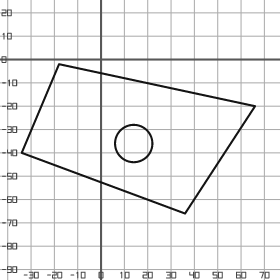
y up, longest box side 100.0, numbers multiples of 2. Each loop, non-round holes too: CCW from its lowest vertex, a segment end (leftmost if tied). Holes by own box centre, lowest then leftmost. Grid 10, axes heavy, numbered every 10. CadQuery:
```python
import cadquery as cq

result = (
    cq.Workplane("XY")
    .moveTo(36.0, -66.0)
    .lineTo(66.0, -20.0)
    .lineTo(-18.0, -2.0)
    .lineTo(-34.0, -40.0)
    .close()
    .moveTo(14.0, -36.0)
    .circle(8.0)
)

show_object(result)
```